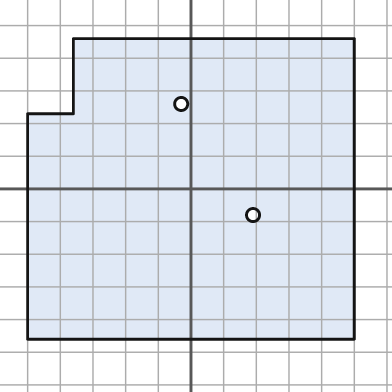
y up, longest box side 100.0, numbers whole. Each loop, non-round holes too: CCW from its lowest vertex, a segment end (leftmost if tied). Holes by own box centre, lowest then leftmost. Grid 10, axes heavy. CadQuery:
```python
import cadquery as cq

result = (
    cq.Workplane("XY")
    .moveTo(-50.0, -46.0)
    .lineTo(50.0, -46.0)
    .lineTo(50.0, 46.0)
    .lineTo(-36.0, 46.0)
    .lineTo(-36.0, 23.0)
    .lineTo(-50.0, 23.0)
    .close()
    .moveTo(19.0, -8.0)
    .circle(2.0)
    .moveTo(-3.0, 26.0)
    .circle(2.0)
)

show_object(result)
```